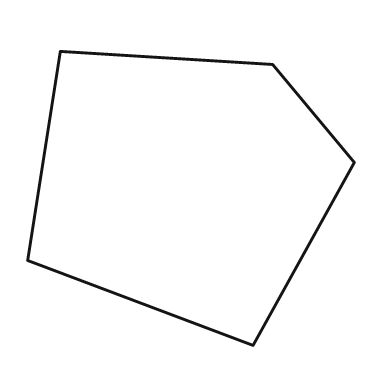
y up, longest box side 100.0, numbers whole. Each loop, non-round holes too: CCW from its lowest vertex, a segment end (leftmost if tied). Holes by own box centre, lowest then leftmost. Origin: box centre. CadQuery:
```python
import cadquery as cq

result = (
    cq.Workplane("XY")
    .moveTo(19.0, -45.0)
    .lineTo(50.0, 11.0)
    .lineTo(25.0, 41.0)
    .lineTo(-40.0, 45.0)
    .lineTo(-50.0, -19.0)
    .close()
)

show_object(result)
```